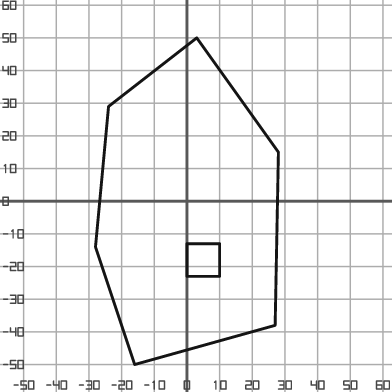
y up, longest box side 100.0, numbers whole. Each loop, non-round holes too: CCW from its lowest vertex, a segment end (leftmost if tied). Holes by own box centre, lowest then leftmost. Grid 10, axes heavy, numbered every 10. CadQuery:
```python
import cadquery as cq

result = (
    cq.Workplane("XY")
    .moveTo(-16.0, -50.0)
    .lineTo(27.0, -38.0)
    .lineTo(28.0, 15.0)
    .lineTo(3.0, 50.0)
    .lineTo(-24.0, 29.0)
    .lineTo(-28.0, -14.0)
    .close()
    .moveTo(0.0, -23.0)
    .lineTo(10.0, -23.0)
    .lineTo(10.0, -13.0)
    .lineTo(0.0, -13.0)
    .close()
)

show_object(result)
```